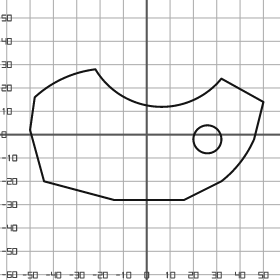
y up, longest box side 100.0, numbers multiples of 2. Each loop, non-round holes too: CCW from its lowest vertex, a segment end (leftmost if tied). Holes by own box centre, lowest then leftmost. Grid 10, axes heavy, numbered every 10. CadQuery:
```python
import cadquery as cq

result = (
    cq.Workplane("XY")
    .moveTo(-14.0, -28.0)
    .lineTo(16.0, -28.0)
    .lineTo(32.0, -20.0)
    .threePointArc((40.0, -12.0), (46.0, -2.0))
    .lineTo(50.0, 14.0)
    .lineTo(32.0, 24.0)
    .threePointArc((4.0, 12.0), (-22.0, 28.0))
    .threePointArc((-36.0, 24.0), (-48.0, 16.0))
    .lineTo(-50.0, 2.0)
    .lineTo(-44.0, -20.0)
    .close()
    .moveTo(26.0, -2.0)
    .circle(6.0)
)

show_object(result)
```